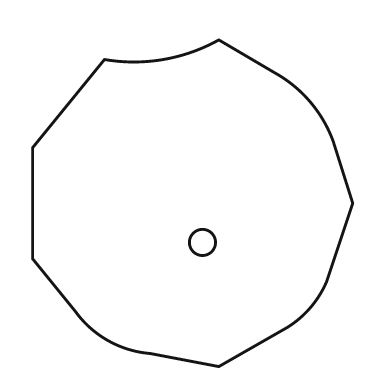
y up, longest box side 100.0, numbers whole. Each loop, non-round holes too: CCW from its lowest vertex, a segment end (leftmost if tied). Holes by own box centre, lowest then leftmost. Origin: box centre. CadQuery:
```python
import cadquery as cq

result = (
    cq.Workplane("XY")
    .moveTo(8.0, -50.0)
    .lineTo(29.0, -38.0)
    .threePointArc((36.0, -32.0), (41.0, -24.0))
    .lineTo(49.0, 0.0)
    .lineTo(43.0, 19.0)
    .threePointArc((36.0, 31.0), (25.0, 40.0))
    .lineTo(8.0, 50.0)
    .threePointArc((-9.0, 44.0), (-27.0, 44.0))
    .lineTo(-49.0, 17.0)
    .lineTo(-49.0, -17.0)
    .lineTo(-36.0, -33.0)
    .threePointArc((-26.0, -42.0), (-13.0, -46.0))
    .close()
    .moveTo(3.0, -12.0)
    .circle(4.0)
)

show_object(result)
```